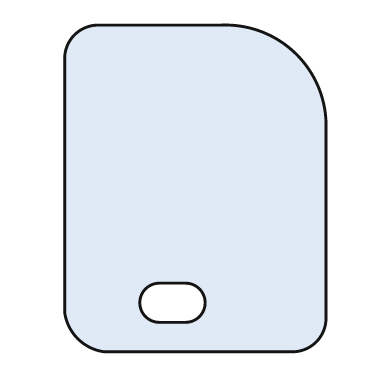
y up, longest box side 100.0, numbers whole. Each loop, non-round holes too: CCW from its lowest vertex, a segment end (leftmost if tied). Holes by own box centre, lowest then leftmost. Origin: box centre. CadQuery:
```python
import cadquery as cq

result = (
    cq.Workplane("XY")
    .moveTo(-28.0, -50.0)
    .lineTo(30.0, -50.0)
    .threePointArc((37.0, -47.0), (40.0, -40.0))
    .lineTo(40.0, 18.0)
    .threePointArc((31.0, 41.0), (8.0, 50.0))
    .lineTo(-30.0, 50.0)
    .threePointArc((-37.0, 47.0), (-40.0, 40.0))
    .lineTo(-40.0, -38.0)
    .threePointArc((-36.0, -46.0), (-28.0, -50.0))
    .close()
    .moveTo(-11.0, -41.0)
    .lineTo(-3.0, -41.0)
    .threePointArc((3.0, -35.0), (-3.0, -29.0))
    .lineTo(-11.0, -29.0)
    .threePointArc((-17.0, -35.0), (-11.0, -41.0))
    .close()
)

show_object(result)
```